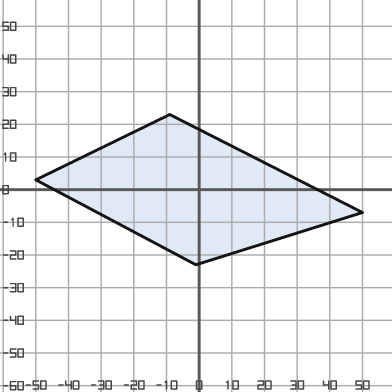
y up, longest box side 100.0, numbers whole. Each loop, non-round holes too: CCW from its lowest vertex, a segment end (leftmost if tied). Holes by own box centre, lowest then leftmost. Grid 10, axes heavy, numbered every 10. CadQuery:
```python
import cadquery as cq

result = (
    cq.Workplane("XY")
    .moveTo(-1.0, -23.0)
    .lineTo(50.0, -7.0)
    .lineTo(-9.0, 23.0)
    .lineTo(-50.0, 3.0)
    .close()
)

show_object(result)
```